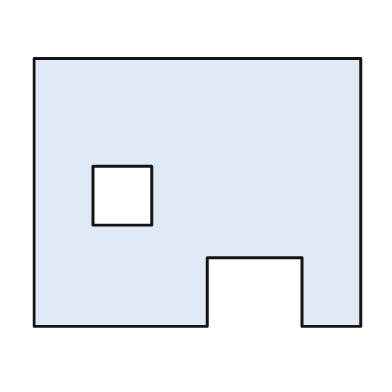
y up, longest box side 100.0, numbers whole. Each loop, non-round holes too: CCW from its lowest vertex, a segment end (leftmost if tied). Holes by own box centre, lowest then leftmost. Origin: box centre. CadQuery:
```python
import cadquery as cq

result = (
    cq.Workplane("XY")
    .moveTo(-50.0, -41.0)
    .lineTo(3.0, -41.0)
    .lineTo(3.0, -20.0)
    .lineTo(32.0, -20.0)
    .lineTo(32.0, -41.0)
    .lineTo(50.0, -41.0)
    .lineTo(50.0, 41.0)
    .lineTo(-50.0, 41.0)
    .close()
    .moveTo(-32.0, -10.0)
    .lineTo(-14.0, -10.0)
    .lineTo(-14.0, 8.0)
    .lineTo(-32.0, 8.0)
    .close()
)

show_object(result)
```